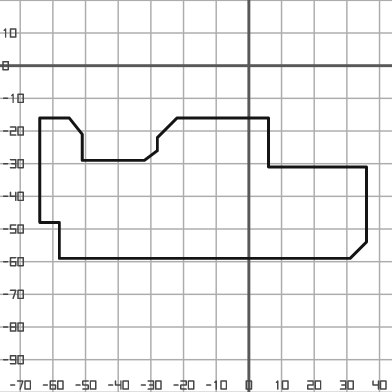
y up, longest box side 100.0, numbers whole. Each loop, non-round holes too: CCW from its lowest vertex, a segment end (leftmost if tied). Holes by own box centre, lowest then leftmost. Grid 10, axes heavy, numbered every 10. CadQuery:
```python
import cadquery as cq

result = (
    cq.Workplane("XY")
    .moveTo(-58.0, -59.0)
    .lineTo(31.0, -59.0)
    .lineTo(36.0, -54.0)
    .lineTo(36.0, -31.0)
    .lineTo(6.0, -31.0)
    .lineTo(6.0, -16.0)
    .lineTo(-22.0, -16.0)
    .lineTo(-28.0, -22.0)
    .lineTo(-28.0, -26.0)
    .lineTo(-32.0, -29.0)
    .lineTo(-51.0, -29.0)
    .lineTo(-51.0, -21.0)
    .lineTo(-55.0, -16.0)
    .lineTo(-64.0, -16.0)
    .lineTo(-64.0, -48.0)
    .lineTo(-58.0, -48.0)
    .close()
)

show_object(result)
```